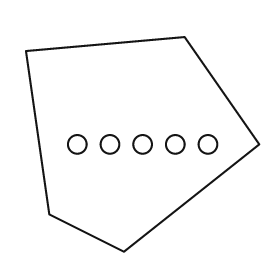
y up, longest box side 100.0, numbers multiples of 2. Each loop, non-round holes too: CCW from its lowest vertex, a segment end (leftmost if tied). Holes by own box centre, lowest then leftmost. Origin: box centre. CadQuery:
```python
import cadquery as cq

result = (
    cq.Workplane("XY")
    .moveTo(-8.0, -46.0)
    .lineTo(50.0, 0.0)
    .lineTo(18.0, 46.0)
    .lineTo(-50.0, 40.0)
    .lineTo(-40.0, -30.0)
    .close()
    .moveTo(-28.0, 0.0)
    .circle(4.0)
    .moveTo(-14.0, 0.0)
    .circle(4.0)
    .moveTo(0.0, 0.0)
    .circle(4.0)
    .moveTo(14.0, 0.0)
    .circle(4.0)
    .moveTo(28.0, 0.0)
    .circle(4.0)
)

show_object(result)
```